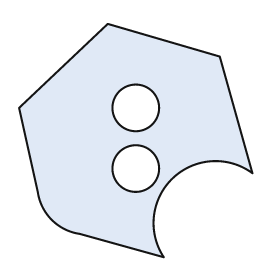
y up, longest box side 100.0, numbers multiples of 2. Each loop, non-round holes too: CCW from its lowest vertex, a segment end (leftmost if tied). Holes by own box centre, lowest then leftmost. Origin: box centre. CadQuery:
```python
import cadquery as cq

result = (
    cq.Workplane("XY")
    .moveTo(12.0, -50.0)
    .threePointArc((16.0, -16.0), (50.0, -14.0))
    .lineTo(36.0, 36.0)
    .lineTo(-12.0, 50.0)
    .lineTo(-50.0, 14.0)
    .lineTo(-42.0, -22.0)
    .threePointArc((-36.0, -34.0), (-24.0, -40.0))
    .close()
    .moveTo(0.0, -12.0)
    .circle(10.0)
    .moveTo(0.0, 14.0)
    .circle(10.0)
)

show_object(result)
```